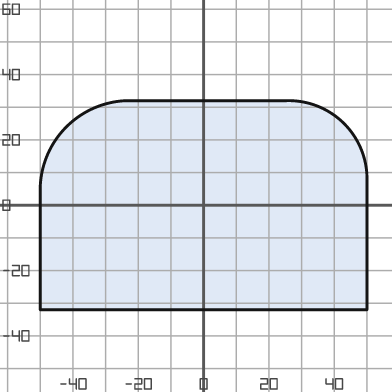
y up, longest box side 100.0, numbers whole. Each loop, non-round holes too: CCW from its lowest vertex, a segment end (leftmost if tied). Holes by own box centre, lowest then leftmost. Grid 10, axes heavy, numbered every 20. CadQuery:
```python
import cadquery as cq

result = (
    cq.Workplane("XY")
    .moveTo(-50.0, -32.0)
    .lineTo(50.0, -32.0)
    .lineTo(50.0, 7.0)
    .threePointArc((43.0, 25.0), (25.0, 32.0))
    .lineTo(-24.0, 32.0)
    .threePointArc((-42.0, 24.0), (-50.0, 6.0))
    .close()
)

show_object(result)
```